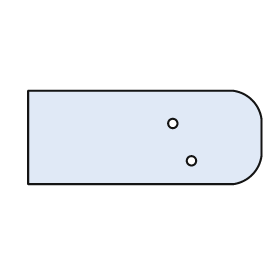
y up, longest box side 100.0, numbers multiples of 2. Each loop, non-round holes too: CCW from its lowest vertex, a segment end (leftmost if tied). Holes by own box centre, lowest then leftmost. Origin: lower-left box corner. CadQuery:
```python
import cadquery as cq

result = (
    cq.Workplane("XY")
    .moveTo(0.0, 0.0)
    .lineTo(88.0, 0.0)
    .threePointArc((96.0, 4.0), (100.0, 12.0))
    .lineTo(100.0, 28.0)
    .threePointArc((96.0, 36.0), (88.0, 40.0))
    .lineTo(0.0, 40.0)
    .close()
    .moveTo(70.0, 10.0)
    .circle(2.0)
    .moveTo(62.0, 26.0)
    .circle(2.0)
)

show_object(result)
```